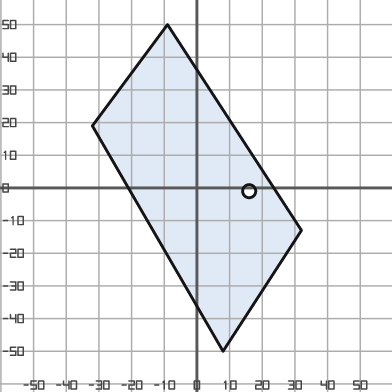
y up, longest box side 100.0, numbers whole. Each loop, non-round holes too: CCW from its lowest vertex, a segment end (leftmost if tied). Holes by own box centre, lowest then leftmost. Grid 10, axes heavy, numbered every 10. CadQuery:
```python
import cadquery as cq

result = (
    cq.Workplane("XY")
    .moveTo(8.0, -50.0)
    .lineTo(32.0, -13.0)
    .lineTo(-9.0, 50.0)
    .lineTo(-32.0, 19.0)
    .close()
    .moveTo(16.0, -1.0)
    .circle(2.0)
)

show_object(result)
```